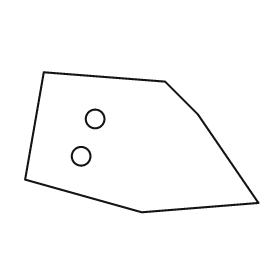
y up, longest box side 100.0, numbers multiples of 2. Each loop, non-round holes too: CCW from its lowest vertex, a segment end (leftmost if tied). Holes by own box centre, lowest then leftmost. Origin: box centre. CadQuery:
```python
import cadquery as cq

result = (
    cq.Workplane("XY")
    .moveTo(0.0, -30.0)
    .lineTo(50.0, -26.0)
    .lineTo(24.0, 12.0)
    .lineTo(10.0, 26.0)
    .lineTo(-42.0, 30.0)
    .lineTo(-50.0, -16.0)
    .close()
    .moveTo(-26.0, -6.0)
    .circle(4.0)
    .moveTo(-20.0, 10.0)
    .circle(4.0)
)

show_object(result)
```